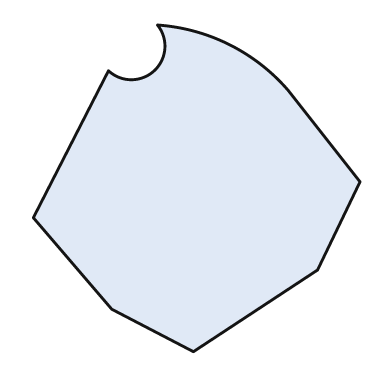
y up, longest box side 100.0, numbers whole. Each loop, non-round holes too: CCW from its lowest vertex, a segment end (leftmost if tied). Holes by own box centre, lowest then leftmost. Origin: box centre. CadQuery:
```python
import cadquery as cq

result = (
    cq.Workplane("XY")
    .moveTo(-1.0, -50.0)
    .lineTo(37.0, -25.0)
    .lineTo(50.0, 2.0)
    .lineTo(28.0, 30.0)
    .threePointArc((10.0, 44.0), (-12.0, 50.0))
    .threePointArc((-13.0, 36.0), (-27.0, 36.0))
    .lineTo(-50.0, -9.0)
    .lineTo(-26.0, -37.0)
    .close()
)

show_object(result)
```